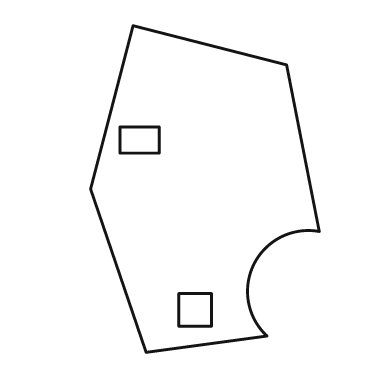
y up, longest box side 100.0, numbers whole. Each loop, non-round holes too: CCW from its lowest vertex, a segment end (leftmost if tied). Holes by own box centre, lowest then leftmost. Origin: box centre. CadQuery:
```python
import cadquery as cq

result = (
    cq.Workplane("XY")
    .moveTo(-18.0, -50.0)
    .lineTo(19.0, -45.0)
    .threePointArc((15.0, -23.0), (35.0, -13.0))
    .lineTo(25.0, 38.0)
    .lineTo(-22.0, 50.0)
    .lineTo(-35.0, 0.0)
    .close()
    .moveTo(-8.0, -42.0)
    .lineTo(2.0, -42.0)
    .lineTo(2.0, -32.0)
    .lineTo(-8.0, -32.0)
    .close()
    .moveTo(-26.0, 11.0)
    .lineTo(-14.0, 11.0)
    .lineTo(-14.0, 19.0)
    .lineTo(-26.0, 19.0)
    .close()
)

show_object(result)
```